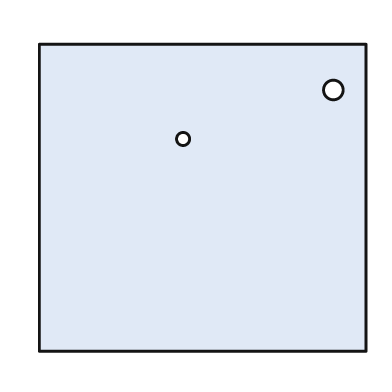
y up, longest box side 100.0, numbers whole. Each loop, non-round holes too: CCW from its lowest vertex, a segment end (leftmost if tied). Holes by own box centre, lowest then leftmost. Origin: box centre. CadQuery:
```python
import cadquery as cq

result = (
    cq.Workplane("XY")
    .moveTo(-50.0, -47.0)
    .lineTo(50.0, -47.0)
    .lineTo(50.0, 47.0)
    .lineTo(-50.0, 47.0)
    .close()
    .moveTo(-6.0, 18.0)
    .circle(2.0)
    .moveTo(40.0, 33.0)
    .circle(3.0)
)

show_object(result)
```